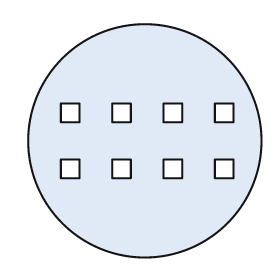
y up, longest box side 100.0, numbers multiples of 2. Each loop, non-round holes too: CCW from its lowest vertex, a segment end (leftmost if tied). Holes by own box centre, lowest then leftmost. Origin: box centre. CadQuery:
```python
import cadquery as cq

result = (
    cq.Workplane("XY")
    .moveTo(0.0, 0.0)
    .circle(50.0)
    .moveTo(-36.0, -16.0)
    .lineTo(-28.0, -16.0)
    .lineTo(-28.0, -8.0)
    .lineTo(-36.0, -8.0)
    .close()
    .moveTo(-14.0, -16.0)
    .lineTo(-6.0, -16.0)
    .lineTo(-6.0, -8.0)
    .lineTo(-14.0, -8.0)
    .close()
    .moveTo(8.0, -16.0)
    .lineTo(16.0, -16.0)
    .lineTo(16.0, -8.0)
    .lineTo(8.0, -8.0)
    .close()
    .moveTo(30.0, -16.0)
    .lineTo(38.0, -16.0)
    .lineTo(38.0, -8.0)
    .lineTo(30.0, -8.0)
    .close()
    .moveTo(-36.0, 8.0)
    .lineTo(-28.0, 8.0)
    .lineTo(-28.0, 16.0)
    .lineTo(-36.0, 16.0)
    .close()
    .moveTo(-14.0, 8.0)
    .lineTo(-6.0, 8.0)
    .lineTo(-6.0, 16.0)
    .lineTo(-14.0, 16.0)
    .close()
    .moveTo(8.0, 8.0)
    .lineTo(16.0, 8.0)
    .lineTo(16.0, 16.0)
    .lineTo(8.0, 16.0)
    .close()
    .moveTo(30.0, 8.0)
    .lineTo(38.0, 8.0)
    .lineTo(38.0, 16.0)
    .lineTo(30.0, 16.0)
    .close()
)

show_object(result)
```